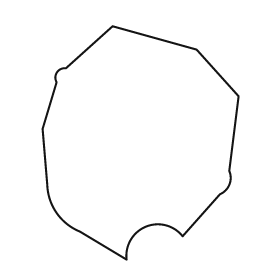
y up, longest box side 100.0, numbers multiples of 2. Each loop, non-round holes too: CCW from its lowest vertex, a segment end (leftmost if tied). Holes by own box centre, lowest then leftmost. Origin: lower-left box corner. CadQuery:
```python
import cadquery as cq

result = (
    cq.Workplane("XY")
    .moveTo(36.0, 0.0)
    .threePointArc((44.0, 14.0), (60.0, 10.0))
    .lineTo(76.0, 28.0)
    .threePointArc((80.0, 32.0), (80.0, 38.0))
    .lineTo(84.0, 70.0)
    .lineTo(66.0, 90.0)
    .lineTo(30.0, 100.0)
    .lineTo(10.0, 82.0)
    .threePointArc((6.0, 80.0), (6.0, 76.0))
    .lineTo(0.0, 56.0)
    .lineTo(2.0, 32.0)
    .threePointArc((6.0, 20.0), (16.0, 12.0))
    .close()
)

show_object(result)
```